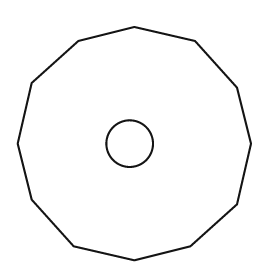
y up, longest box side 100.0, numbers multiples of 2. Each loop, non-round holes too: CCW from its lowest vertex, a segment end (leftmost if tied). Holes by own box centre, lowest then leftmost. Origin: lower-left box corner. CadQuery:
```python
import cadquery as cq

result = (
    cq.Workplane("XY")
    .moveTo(50.0, 0.0)
    .lineTo(74.0, 6.0)
    .lineTo(94.0, 24.0)
    .lineTo(100.0, 50.0)
    .lineTo(94.0, 74.0)
    .lineTo(76.0, 94.0)
    .lineTo(50.0, 100.0)
    .lineTo(26.0, 94.0)
    .lineTo(6.0, 76.0)
    .lineTo(0.0, 50.0)
    .lineTo(6.0, 26.0)
    .lineTo(24.0, 6.0)
    .close()
    .moveTo(48.0, 50.0)
    .circle(10.0)
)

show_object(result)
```